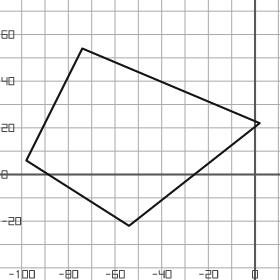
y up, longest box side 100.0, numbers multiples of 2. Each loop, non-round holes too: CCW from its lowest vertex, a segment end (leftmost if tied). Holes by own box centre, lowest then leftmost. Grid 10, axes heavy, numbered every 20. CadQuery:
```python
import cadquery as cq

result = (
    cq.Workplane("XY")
    .moveTo(-54.0, -22.0)
    .lineTo(2.0, 22.0)
    .lineTo(-74.0, 54.0)
    .lineTo(-98.0, 6.0)
    .close()
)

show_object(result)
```